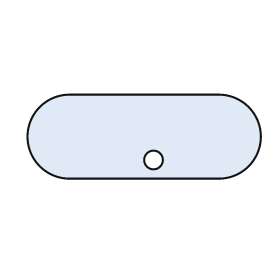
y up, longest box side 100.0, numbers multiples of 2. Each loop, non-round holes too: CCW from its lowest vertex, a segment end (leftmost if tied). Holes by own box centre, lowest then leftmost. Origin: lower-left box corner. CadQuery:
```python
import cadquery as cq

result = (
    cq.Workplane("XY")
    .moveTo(18.0, 0.0)
    .lineTo(82.0, 0.0)
    .threePointArc((100.0, 18.0), (82.0, 36.0))
    .lineTo(18.0, 36.0)
    .threePointArc((0.0, 18.0), (18.0, 0.0))
    .close()
    .moveTo(54.0, 8.0)
    .circle(4.0)
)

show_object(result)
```